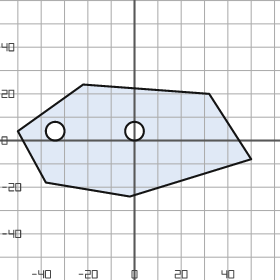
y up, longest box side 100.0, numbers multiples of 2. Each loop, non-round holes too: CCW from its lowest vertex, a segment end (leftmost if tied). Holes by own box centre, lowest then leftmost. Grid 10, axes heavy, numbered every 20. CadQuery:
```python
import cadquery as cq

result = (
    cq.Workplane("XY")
    .moveTo(-2.0, -24.0)
    .lineTo(50.0, -8.0)
    .lineTo(32.0, 20.0)
    .lineTo(-22.0, 24.0)
    .lineTo(-50.0, 4.0)
    .lineTo(-38.0, -18.0)
    .close()
    .moveTo(-34.0, 4.0)
    .circle(4.0)
    .moveTo(0.0, 4.0)
    .circle(4.0)
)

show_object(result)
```